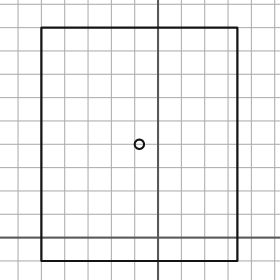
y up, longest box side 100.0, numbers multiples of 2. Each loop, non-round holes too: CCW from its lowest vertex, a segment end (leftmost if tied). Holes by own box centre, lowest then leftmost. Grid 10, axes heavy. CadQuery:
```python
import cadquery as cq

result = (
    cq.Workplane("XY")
    .moveTo(-50.0, -10.0)
    .lineTo(34.0, -10.0)
    .lineTo(34.0, 90.0)
    .lineTo(-50.0, 90.0)
    .close()
    .moveTo(-8.0, 40.0)
    .circle(2.0)
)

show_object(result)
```